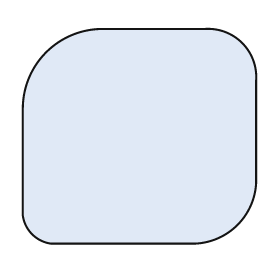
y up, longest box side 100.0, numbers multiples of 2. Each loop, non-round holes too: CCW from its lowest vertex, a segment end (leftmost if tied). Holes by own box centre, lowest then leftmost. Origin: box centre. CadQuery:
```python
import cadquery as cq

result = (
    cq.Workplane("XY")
    .moveTo(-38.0, -46.0)
    .lineTo(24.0, -46.0)
    .threePointArc((42.0, -38.0), (50.0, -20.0))
    .lineTo(50.0, 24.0)
    .threePointArc((44.0, 40.0), (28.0, 46.0))
    .lineTo(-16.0, 46.0)
    .threePointArc((-40.0, 36.0), (-50.0, 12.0))
    .lineTo(-50.0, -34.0)
    .threePointArc((-46.0, -42.0), (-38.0, -46.0))
    .close()
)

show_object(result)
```